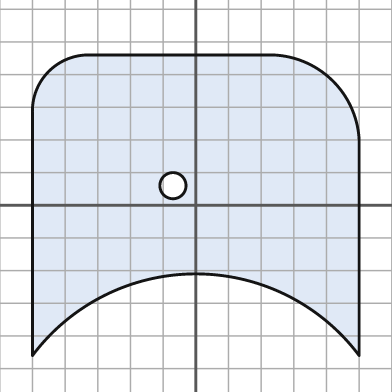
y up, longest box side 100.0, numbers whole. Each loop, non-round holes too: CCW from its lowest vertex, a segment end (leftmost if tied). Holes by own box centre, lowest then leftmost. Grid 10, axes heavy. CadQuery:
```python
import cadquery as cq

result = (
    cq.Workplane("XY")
    .moveTo(-50.0, -46.0)
    .threePointArc((0.0, -21.0), (50.0, -46.0))
    .lineTo(50.0, 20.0)
    .threePointArc((42.0, 38.0), (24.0, 46.0))
    .lineTo(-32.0, 46.0)
    .threePointArc((-45.0, 41.0), (-50.0, 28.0))
    .close()
    .moveTo(-7.0, 6.0)
    .circle(4.0)
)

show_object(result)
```